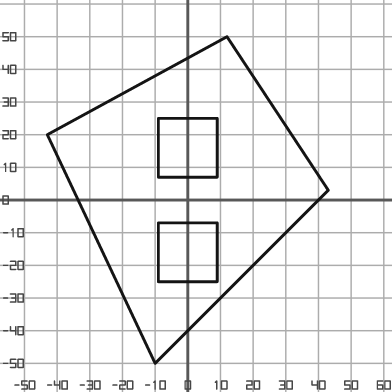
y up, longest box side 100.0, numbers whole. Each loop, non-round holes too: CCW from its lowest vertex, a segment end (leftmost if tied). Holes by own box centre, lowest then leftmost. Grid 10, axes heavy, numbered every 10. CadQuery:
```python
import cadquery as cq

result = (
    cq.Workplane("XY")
    .moveTo(-10.0, -50.0)
    .lineTo(43.0, 3.0)
    .lineTo(12.0, 50.0)
    .lineTo(-43.0, 20.0)
    .close()
    .moveTo(-9.0, -25.0)
    .lineTo(9.0, -25.0)
    .lineTo(9.0, -7.0)
    .lineTo(-9.0, -7.0)
    .close()
    .moveTo(-9.0, 7.0)
    .lineTo(9.0, 7.0)
    .lineTo(9.0, 25.0)
    .lineTo(-9.0, 25.0)
    .close()
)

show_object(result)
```